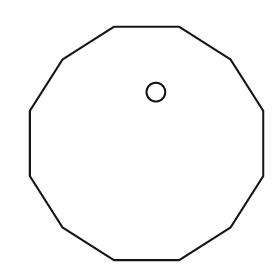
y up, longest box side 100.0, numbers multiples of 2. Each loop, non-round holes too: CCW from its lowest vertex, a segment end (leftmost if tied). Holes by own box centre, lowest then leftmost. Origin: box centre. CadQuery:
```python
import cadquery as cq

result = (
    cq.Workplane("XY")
    .moveTo(-14.0, -50.0)
    .lineTo(14.0, -50.0)
    .lineTo(36.0, -36.0)
    .lineTo(50.0, -14.0)
    .lineTo(50.0, 14.0)
    .lineTo(36.0, 36.0)
    .lineTo(14.0, 50.0)
    .lineTo(-14.0, 50.0)
    .lineTo(-36.0, 36.0)
    .lineTo(-50.0, 14.0)
    .lineTo(-50.0, -14.0)
    .lineTo(-36.0, -36.0)
    .close()
    .moveTo(4.0, 22.0)
    .circle(4.0)
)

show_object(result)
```